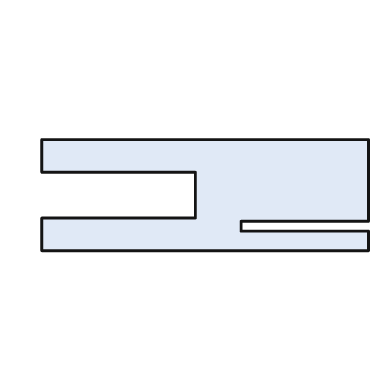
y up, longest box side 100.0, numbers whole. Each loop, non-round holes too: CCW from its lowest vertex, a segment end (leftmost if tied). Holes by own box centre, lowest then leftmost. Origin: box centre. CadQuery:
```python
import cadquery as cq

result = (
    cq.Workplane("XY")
    .moveTo(-50.0, -17.0)
    .lineTo(50.0, -17.0)
    .lineTo(50.0, -11.0)
    .lineTo(11.0, -11.0)
    .lineTo(11.0, -8.0)
    .lineTo(50.0, -8.0)
    .lineTo(50.0, 17.0)
    .lineTo(-50.0, 17.0)
    .lineTo(-50.0, 7.0)
    .lineTo(-3.0, 7.0)
    .lineTo(-3.0, -7.0)
    .lineTo(-50.0, -7.0)
    .close()
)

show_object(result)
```